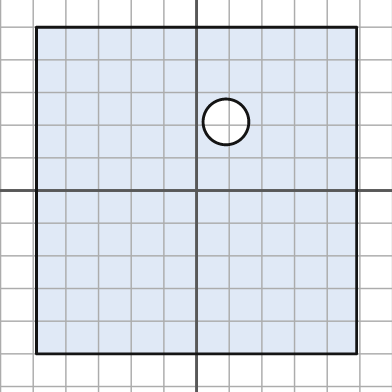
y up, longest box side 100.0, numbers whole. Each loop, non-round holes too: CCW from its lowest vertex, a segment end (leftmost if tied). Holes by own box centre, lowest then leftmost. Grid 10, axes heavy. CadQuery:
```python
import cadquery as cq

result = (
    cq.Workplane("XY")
    .moveTo(-49.0, -50.0)
    .lineTo(49.0, -50.0)
    .lineTo(49.0, 50.0)
    .lineTo(-49.0, 50.0)
    .close()
    .moveTo(9.0, 21.0)
    .circle(7.0)
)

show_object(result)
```